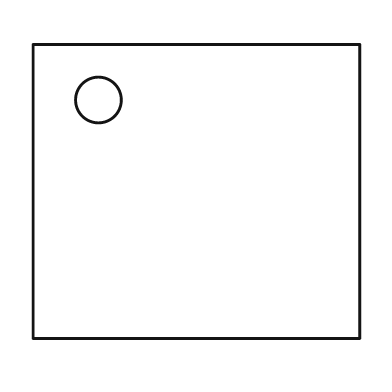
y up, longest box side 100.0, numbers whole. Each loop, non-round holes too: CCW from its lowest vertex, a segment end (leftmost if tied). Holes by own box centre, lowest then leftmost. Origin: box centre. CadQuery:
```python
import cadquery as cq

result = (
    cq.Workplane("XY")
    .moveTo(-50.0, -45.0)
    .lineTo(50.0, -45.0)
    .lineTo(50.0, 45.0)
    .lineTo(-50.0, 45.0)
    .close()
    .moveTo(-30.0, 28.0)
    .circle(7.0)
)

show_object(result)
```